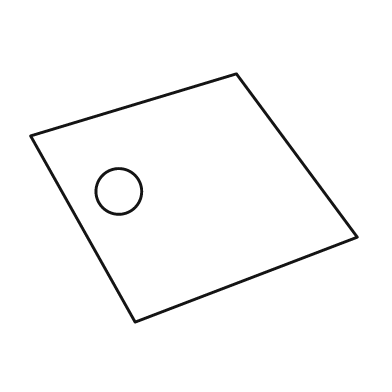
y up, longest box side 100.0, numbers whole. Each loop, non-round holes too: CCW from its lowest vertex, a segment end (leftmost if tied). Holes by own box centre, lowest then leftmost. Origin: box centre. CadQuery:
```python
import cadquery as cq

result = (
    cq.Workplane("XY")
    .moveTo(-18.0, -38.0)
    .lineTo(50.0, -12.0)
    .lineTo(13.0, 38.0)
    .lineTo(-50.0, 19.0)
    .close()
    .moveTo(-23.0, 2.0)
    .circle(7.0)
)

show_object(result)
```